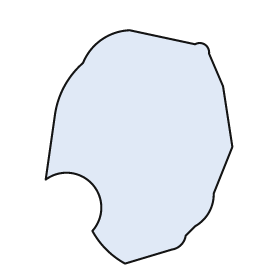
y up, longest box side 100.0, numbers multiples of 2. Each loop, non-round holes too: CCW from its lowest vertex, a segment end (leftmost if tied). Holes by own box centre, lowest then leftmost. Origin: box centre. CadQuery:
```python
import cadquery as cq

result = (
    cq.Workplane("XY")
    .moveTo(-6.0, -50.0)
    .lineTo(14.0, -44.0)
    .threePointArc((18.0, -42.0), (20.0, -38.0))
    .lineTo(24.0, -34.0)
    .threePointArc((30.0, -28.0), (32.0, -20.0))
    .lineTo(40.0, 0.0)
    .lineTo(36.0, 26.0)
    .lineTo(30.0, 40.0)
    .threePointArc((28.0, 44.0), (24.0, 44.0))
    .lineTo(-4.0, 50.0)
    .threePointArc((-16.0, 46.0), (-24.0, 36.0))
    .threePointArc((-32.0, 26.0), (-36.0, 14.0))
    .lineTo(-40.0, -14.0)
    .threePointArc((-20.0, -16.0), (-20.0, -36.0))
    .threePointArc((-14.0, -44.0), (-6.0, -50.0))
    .close()
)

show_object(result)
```